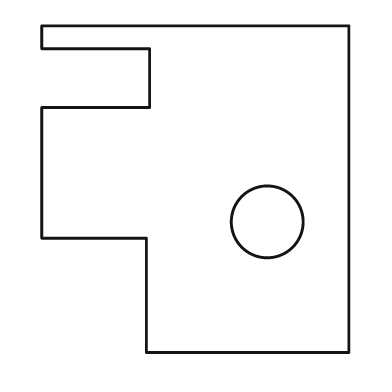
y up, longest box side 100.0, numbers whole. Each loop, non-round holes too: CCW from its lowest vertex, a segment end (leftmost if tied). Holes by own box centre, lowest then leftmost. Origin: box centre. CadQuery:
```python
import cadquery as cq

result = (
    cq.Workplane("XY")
    .moveTo(-15.0, -50.0)
    .lineTo(47.0, -50.0)
    .lineTo(47.0, 50.0)
    .lineTo(-47.0, 50.0)
    .lineTo(-47.0, 43.0)
    .lineTo(-14.0, 43.0)
    .lineTo(-14.0, 25.0)
    .lineTo(-47.0, 25.0)
    .lineTo(-47.0, -15.0)
    .lineTo(-15.0, -15.0)
    .close()
    .moveTo(22.0, -10.0)
    .circle(11.0)
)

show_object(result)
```